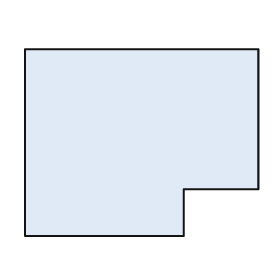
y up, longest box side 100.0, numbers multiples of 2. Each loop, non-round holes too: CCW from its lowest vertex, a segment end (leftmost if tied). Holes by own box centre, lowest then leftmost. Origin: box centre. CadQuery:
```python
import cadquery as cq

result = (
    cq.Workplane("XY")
    .moveTo(-50.0, -40.0)
    .lineTo(18.0, -40.0)
    .lineTo(18.0, -20.0)
    .lineTo(50.0, -20.0)
    .lineTo(50.0, 40.0)
    .lineTo(-50.0, 40.0)
    .close()
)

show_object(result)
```